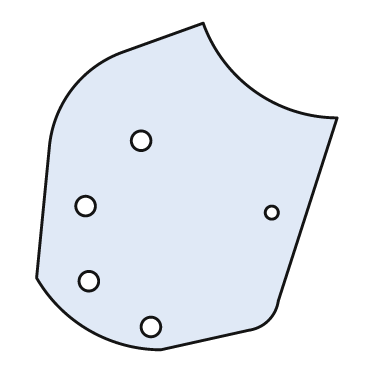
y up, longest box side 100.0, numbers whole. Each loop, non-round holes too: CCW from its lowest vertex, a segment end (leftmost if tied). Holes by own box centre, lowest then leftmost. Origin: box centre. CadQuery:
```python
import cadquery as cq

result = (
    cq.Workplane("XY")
    .moveTo(-8.0, -50.0)
    .lineTo(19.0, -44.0)
    .threePointArc((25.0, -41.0), (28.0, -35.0))
    .lineTo(46.0, 21.0)
    .threePointArc((21.0, 29.0), (5.0, 50.0))
    .lineTo(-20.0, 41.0)
    .threePointArc((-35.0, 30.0), (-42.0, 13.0))
    .lineTo(-46.0, -28.0)
    .threePointArc((-30.0, -44.0), (-8.0, -50.0))
    .close()
    .moveTo(-11.0, -43.0)
    .circle(3.0)
    .moveTo(-30.0, -29.0)
    .circle(3.0)
    .moveTo(26.0, -8.0)
    .circle(2.0)
    .moveTo(-31.0, -6.0)
    .circle(3.0)
    .moveTo(-14.0, 14.0)
    .circle(3.0)
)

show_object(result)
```